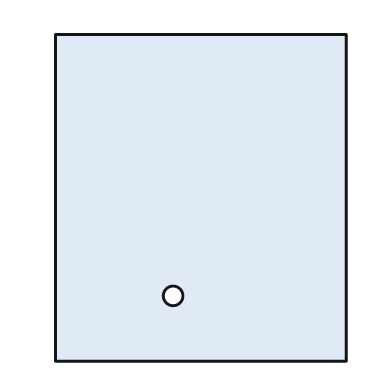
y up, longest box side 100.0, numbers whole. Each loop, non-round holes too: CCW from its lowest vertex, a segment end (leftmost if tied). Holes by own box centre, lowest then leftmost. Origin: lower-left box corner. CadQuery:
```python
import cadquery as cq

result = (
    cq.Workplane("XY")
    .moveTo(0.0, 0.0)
    .lineTo(89.0, 0.0)
    .lineTo(89.0, 100.0)
    .lineTo(0.0, 100.0)
    .close()
    .moveTo(36.0, 20.0)
    .circle(3.0)
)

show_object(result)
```